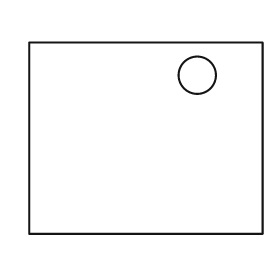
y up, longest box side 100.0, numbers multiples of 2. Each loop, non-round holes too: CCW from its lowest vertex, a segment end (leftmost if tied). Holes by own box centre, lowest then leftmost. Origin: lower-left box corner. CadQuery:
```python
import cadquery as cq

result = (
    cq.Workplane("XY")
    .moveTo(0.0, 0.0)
    .lineTo(100.0, 0.0)
    .lineTo(100.0, 82.0)
    .lineTo(0.0, 82.0)
    .close()
    .moveTo(72.0, 68.0)
    .circle(8.0)
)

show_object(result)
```